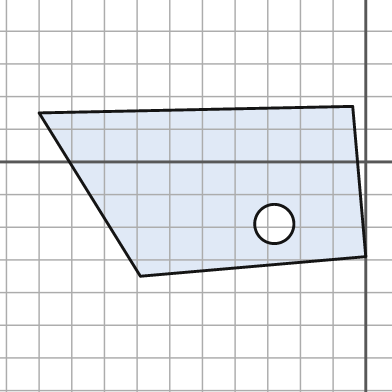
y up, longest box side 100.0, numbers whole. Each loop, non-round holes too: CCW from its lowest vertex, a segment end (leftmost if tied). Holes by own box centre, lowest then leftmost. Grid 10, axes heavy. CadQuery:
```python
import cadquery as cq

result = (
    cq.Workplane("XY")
    .moveTo(-69.0, -35.0)
    .lineTo(0.0, -29.0)
    .lineTo(-4.0, 17.0)
    .lineTo(-100.0, 15.0)
    .close()
    .moveTo(-28.0, -19.0)
    .circle(6.0)
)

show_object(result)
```